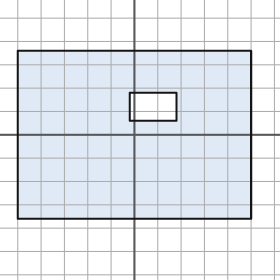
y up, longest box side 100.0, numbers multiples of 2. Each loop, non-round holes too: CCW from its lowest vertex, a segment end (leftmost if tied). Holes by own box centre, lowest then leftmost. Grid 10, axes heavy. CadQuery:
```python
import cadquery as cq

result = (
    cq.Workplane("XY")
    .moveTo(-50.0, -36.0)
    .lineTo(50.0, -36.0)
    .lineTo(50.0, 36.0)
    .lineTo(-50.0, 36.0)
    .close()
    .moveTo(-2.0, 6.0)
    .lineTo(18.0, 6.0)
    .lineTo(18.0, 18.0)
    .lineTo(-2.0, 18.0)
    .close()
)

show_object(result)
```